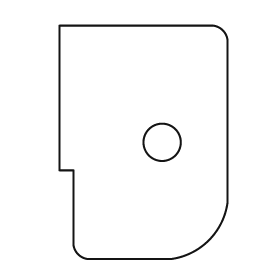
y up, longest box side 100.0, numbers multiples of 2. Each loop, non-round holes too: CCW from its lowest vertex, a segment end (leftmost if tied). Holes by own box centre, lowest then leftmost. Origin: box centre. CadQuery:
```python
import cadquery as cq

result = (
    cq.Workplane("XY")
    .moveTo(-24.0, -50.0)
    .lineTo(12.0, -50.0)
    .threePointArc((28.0, -42.0), (36.0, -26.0))
    .lineTo(36.0, 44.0)
    .threePointArc((34.0, 48.0), (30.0, 50.0))
    .lineTo(-36.0, 50.0)
    .lineTo(-36.0, -12.0)
    .lineTo(-30.0, -12.0)
    .lineTo(-30.0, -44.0)
    .threePointArc((-28.0, -48.0), (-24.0, -50.0))
    .close()
    .moveTo(8.0, 0.0)
    .circle(8.0)
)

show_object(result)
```